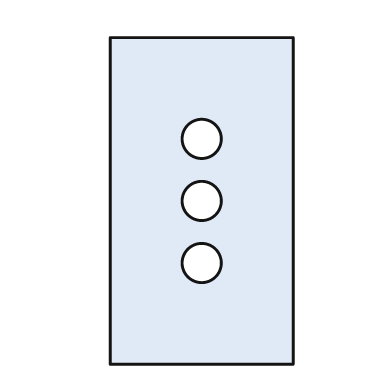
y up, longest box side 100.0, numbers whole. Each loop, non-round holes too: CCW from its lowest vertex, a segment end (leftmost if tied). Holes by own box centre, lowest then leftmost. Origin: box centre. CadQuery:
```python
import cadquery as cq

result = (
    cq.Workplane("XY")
    .moveTo(-28.0, -50.0)
    .lineTo(28.0, -50.0)
    .lineTo(28.0, 50.0)
    .lineTo(-28.0, 50.0)
    .close()
    .moveTo(0.0, -19.0)
    .circle(6.0)
    .moveTo(0.0, 0.0)
    .circle(6.0)
    .moveTo(0.0, 19.0)
    .circle(6.0)
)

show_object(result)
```